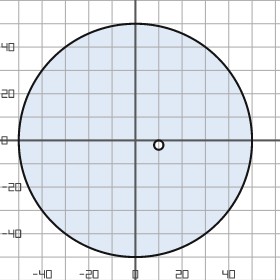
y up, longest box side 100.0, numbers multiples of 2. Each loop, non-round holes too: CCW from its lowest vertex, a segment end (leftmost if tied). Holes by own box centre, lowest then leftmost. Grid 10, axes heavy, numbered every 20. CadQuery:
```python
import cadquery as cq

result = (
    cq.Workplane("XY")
    .moveTo(0.0, 0.0)
    .circle(50.0)
    .moveTo(10.0, -2.0)
    .circle(2.0)
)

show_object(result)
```